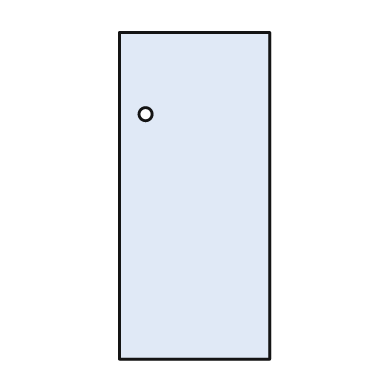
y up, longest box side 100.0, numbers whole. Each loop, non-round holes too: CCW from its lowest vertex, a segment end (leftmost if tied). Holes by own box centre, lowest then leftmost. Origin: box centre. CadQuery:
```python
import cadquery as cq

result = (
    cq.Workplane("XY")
    .moveTo(-23.0, -50.0)
    .lineTo(23.0, -50.0)
    .lineTo(23.0, 50.0)
    .lineTo(-23.0, 50.0)
    .close()
    .moveTo(-15.0, 25.0)
    .circle(2.0)
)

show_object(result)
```